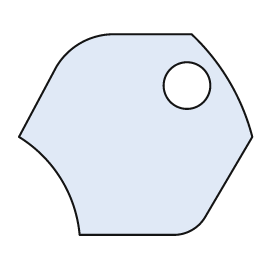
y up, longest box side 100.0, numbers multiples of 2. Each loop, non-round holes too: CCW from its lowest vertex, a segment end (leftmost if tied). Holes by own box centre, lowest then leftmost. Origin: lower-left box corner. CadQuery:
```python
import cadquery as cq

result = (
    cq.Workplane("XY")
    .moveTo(26.0, 0.0)
    .lineTo(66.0, 0.0)
    .threePointArc((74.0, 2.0), (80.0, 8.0))
    .lineTo(100.0, 42.0)
    .threePointArc((90.0, 66.0), (74.0, 86.0))
    .lineTo(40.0, 86.0)
    .threePointArc((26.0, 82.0), (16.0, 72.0))
    .lineTo(0.0, 42.0)
    .threePointArc((18.0, 24.0), (26.0, 0.0))
    .close()
    .moveTo(72.0, 64.0)
    .circle(10.0)
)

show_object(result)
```